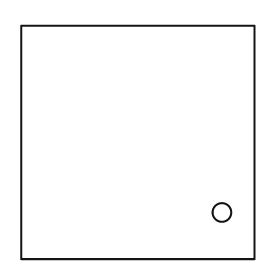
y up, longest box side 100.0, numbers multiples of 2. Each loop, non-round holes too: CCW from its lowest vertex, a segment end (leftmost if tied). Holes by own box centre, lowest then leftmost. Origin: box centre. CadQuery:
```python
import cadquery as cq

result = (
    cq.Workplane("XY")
    .moveTo(-50.0, -50.0)
    .lineTo(50.0, -50.0)
    .lineTo(50.0, 50.0)
    .lineTo(-50.0, 50.0)
    .close()
    .moveTo(36.0, -30.0)
    .circle(4.0)
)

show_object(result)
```